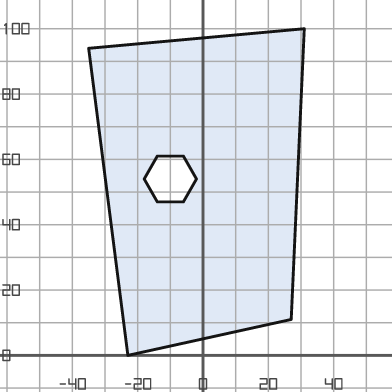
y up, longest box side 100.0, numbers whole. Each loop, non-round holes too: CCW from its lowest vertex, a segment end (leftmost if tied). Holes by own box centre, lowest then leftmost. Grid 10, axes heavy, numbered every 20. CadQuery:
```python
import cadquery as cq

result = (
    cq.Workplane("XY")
    .moveTo(-23.0, 0.0)
    .lineTo(27.0, 11.0)
    .lineTo(31.0, 100.0)
    .lineTo(-35.0, 94.0)
    .close()
    .moveTo(-14.0, 47.0)
    .lineTo(-6.0, 47.0)
    .lineTo(-2.0, 54.0)
    .lineTo(-6.0, 61.0)
    .lineTo(-14.0, 61.0)
    .lineTo(-18.0, 54.0)
    .close()
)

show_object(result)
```